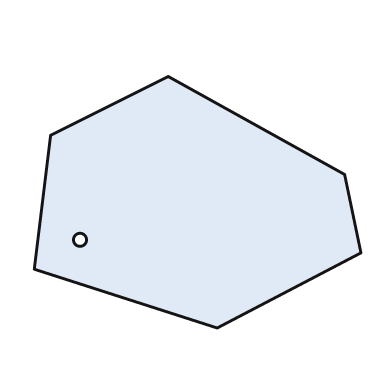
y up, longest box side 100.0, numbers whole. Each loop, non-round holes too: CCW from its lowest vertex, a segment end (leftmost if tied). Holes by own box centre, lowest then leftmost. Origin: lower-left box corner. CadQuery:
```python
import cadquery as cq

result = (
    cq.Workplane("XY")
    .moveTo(56.0, 0.0)
    .lineTo(100.0, 23.0)
    .lineTo(95.0, 47.0)
    .lineTo(41.0, 77.0)
    .lineTo(5.0, 59.0)
    .lineTo(0.0, 18.0)
    .close()
    .moveTo(14.0, 27.0)
    .circle(2.0)
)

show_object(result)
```